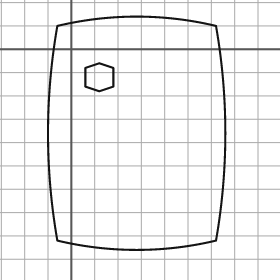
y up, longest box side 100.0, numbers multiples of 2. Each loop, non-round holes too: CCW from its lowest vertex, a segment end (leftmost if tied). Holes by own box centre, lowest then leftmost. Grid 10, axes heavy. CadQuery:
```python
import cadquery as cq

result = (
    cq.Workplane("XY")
    .moveTo(-6.0, -82.0)
    .threePointArc((28.0, -86.0), (62.0, -82.0))
    .threePointArc((66.0, -36.0), (62.0, 10.0))
    .threePointArc((28.0, 14.0), (-6.0, 10.0))
    .threePointArc((-10.0, -36.0), (-6.0, -82.0))
    .close()
    .moveTo(12.0, -18.0)
    .lineTo(18.0, -16.0)
    .lineTo(18.0, -8.0)
    .lineTo(12.0, -6.0)
    .lineTo(6.0, -8.0)
    .lineTo(6.0, -16.0)
    .close()
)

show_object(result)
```